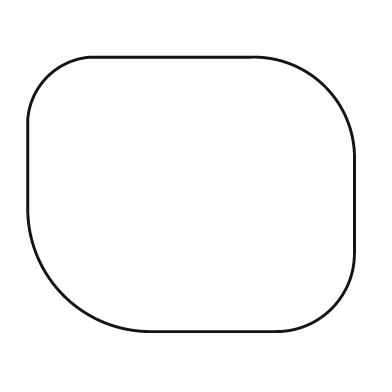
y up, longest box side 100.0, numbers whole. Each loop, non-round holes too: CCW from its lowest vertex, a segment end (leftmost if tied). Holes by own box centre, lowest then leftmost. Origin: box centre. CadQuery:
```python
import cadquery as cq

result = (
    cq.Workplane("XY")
    .moveTo(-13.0, -42.0)
    .lineTo(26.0, -42.0)
    .threePointArc((43.0, -35.0), (50.0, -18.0))
    .lineTo(50.0, 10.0)
    .threePointArc((41.0, 33.0), (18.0, 42.0))
    .lineTo(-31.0, 42.0)
    .threePointArc((-44.0, 36.0), (-50.0, 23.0))
    .lineTo(-50.0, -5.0)
    .threePointArc((-39.0, -31.0), (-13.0, -42.0))
    .close()
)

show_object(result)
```